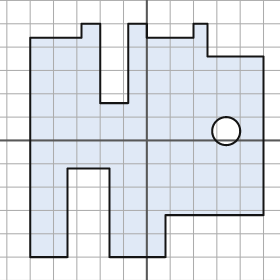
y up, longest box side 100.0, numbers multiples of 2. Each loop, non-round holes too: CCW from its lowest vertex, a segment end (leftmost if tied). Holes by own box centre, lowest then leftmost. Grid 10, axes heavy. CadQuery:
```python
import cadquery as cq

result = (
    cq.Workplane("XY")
    .moveTo(-50.0, -50.0)
    .lineTo(-34.0, -50.0)
    .lineTo(-34.0, -12.0)
    .lineTo(-16.0, -12.0)
    .lineTo(-16.0, -50.0)
    .lineTo(8.0, -50.0)
    .lineTo(8.0, -32.0)
    .lineTo(50.0, -32.0)
    .lineTo(50.0, 36.0)
    .lineTo(26.0, 36.0)
    .lineTo(26.0, 50.0)
    .lineTo(20.0, 50.0)
    .lineTo(20.0, 44.0)
    .lineTo(0.0, 44.0)
    .lineTo(0.0, 50.0)
    .lineTo(-8.0, 50.0)
    .lineTo(-8.0, 16.0)
    .lineTo(-20.0, 16.0)
    .lineTo(-20.0, 50.0)
    .lineTo(-28.0, 50.0)
    .lineTo(-28.0, 44.0)
    .lineTo(-50.0, 44.0)
    .close()
    .moveTo(34.0, 4.0)
    .circle(6.0)
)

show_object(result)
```